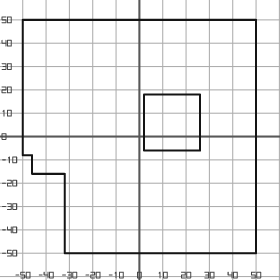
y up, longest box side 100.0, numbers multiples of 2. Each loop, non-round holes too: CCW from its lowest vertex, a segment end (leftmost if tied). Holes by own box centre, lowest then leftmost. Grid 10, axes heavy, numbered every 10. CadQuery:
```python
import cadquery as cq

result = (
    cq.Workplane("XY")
    .moveTo(-32.0, -50.0)
    .lineTo(50.0, -50.0)
    .lineTo(50.0, 50.0)
    .lineTo(-50.0, 50.0)
    .lineTo(-50.0, -8.0)
    .lineTo(-46.0, -8.0)
    .lineTo(-46.0, -16.0)
    .lineTo(-32.0, -16.0)
    .close()
    .moveTo(2.0, -6.0)
    .lineTo(26.0, -6.0)
    .lineTo(26.0, 18.0)
    .lineTo(2.0, 18.0)
    .close()
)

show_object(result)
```